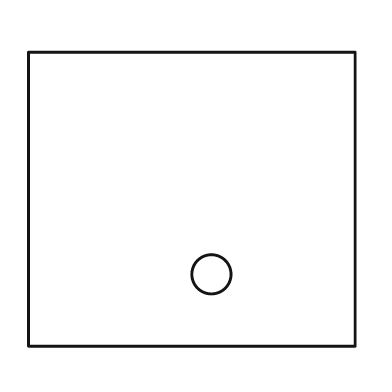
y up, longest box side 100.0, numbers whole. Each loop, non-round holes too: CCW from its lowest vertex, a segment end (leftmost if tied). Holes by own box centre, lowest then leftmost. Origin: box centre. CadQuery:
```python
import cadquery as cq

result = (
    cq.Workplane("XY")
    .moveTo(-50.0, -45.0)
    .lineTo(50.0, -45.0)
    .lineTo(50.0, 45.0)
    .lineTo(-50.0, 45.0)
    .close()
    .moveTo(6.0, -23.0)
    .circle(6.0)
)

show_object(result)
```